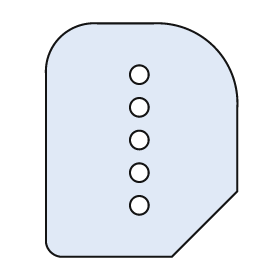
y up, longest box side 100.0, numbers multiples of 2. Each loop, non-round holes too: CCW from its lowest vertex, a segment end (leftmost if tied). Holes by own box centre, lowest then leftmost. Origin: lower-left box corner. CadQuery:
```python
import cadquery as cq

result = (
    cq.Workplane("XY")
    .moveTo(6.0, 0.0)
    .lineTo(54.0, 0.0)
    .lineTo(82.0, 28.0)
    .lineTo(82.0, 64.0)
    .threePointArc((72.0, 90.0), (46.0, 100.0))
    .lineTo(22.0, 100.0)
    .threePointArc((6.0, 94.0), (0.0, 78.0))
    .lineTo(0.0, 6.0)
    .threePointArc((2.0, 2.0), (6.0, 0.0))
    .close()
    .moveTo(40.0, 22.0)
    .circle(4.0)
    .moveTo(40.0, 36.0)
    .circle(4.0)
    .moveTo(40.0, 50.0)
    .circle(4.0)
    .moveTo(40.0, 64.0)
    .circle(4.0)
    .moveTo(40.0, 78.0)
    .circle(4.0)
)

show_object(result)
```